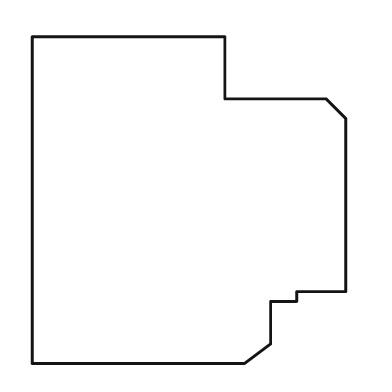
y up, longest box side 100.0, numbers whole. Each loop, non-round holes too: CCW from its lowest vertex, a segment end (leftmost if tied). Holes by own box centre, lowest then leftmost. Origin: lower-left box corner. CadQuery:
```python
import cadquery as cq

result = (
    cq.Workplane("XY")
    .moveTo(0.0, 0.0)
    .lineTo(65.0, 0.0)
    .lineTo(73.0, 6.0)
    .lineTo(73.0, 19.0)
    .lineTo(81.0, 19.0)
    .lineTo(81.0, 22.0)
    .lineTo(96.0, 22.0)
    .lineTo(96.0, 75.0)
    .lineTo(90.0, 81.0)
    .lineTo(59.0, 81.0)
    .lineTo(59.0, 100.0)
    .lineTo(0.0, 100.0)
    .close()
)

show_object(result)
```